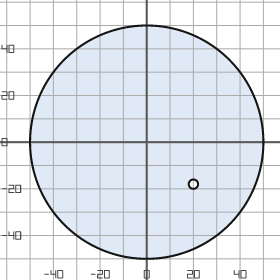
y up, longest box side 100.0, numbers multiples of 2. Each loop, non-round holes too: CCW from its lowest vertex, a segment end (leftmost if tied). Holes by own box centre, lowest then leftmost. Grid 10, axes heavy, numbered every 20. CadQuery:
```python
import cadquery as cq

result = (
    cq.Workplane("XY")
    .moveTo(0.0, 0.0)
    .circle(50.0)
    .moveTo(20.0, -18.0)
    .circle(2.0)
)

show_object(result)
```